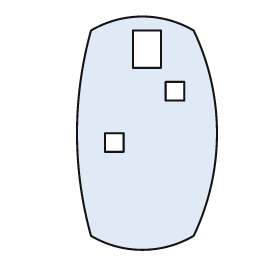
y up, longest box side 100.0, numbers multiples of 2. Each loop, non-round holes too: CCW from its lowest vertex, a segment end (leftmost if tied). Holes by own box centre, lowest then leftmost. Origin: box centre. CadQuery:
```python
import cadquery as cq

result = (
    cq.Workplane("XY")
    .moveTo(-24.0, -44.0)
    .threePointArc((-2.0, -50.0), (20.0, -44.0))
    .threePointArc((30.0, 0.0), (20.0, 44.0))
    .threePointArc((-2.0, 50.0), (-24.0, 44.0))
    .threePointArc((-30.0, 0.0), (-24.0, -44.0))
    .close()
    .moveTo(-18.0, -8.0)
    .lineTo(-10.0, -8.0)
    .lineTo(-10.0, 0.0)
    .lineTo(-18.0, 0.0)
    .close()
    .moveTo(8.0, 14.0)
    .lineTo(16.0, 14.0)
    .lineTo(16.0, 22.0)
    .lineTo(8.0, 22.0)
    .close()
    .moveTo(-6.0, 28.0)
    .lineTo(6.0, 28.0)
    .lineTo(6.0, 44.0)
    .lineTo(-6.0, 44.0)
    .close()
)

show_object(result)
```